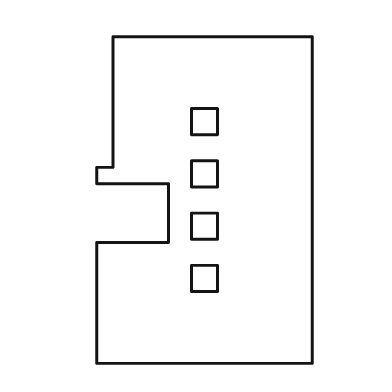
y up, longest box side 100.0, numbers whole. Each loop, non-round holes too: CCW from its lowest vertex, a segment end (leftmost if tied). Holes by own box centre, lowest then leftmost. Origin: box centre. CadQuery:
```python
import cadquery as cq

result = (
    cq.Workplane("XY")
    .moveTo(-33.0, -50.0)
    .lineTo(33.0, -50.0)
    .lineTo(33.0, 50.0)
    .lineTo(-28.0, 50.0)
    .lineTo(-28.0, 10.0)
    .lineTo(-33.0, 10.0)
    .lineTo(-33.0, 5.0)
    .lineTo(-11.0, 5.0)
    .lineTo(-11.0, -13.0)
    .lineTo(-33.0, -13.0)
    .close()
    .moveTo(-4.0, -28.0)
    .lineTo(4.0, -28.0)
    .lineTo(4.0, -20.0)
    .lineTo(-4.0, -20.0)
    .close()
    .moveTo(-4.0, -12.0)
    .lineTo(4.0, -12.0)
    .lineTo(4.0, -4.0)
    .lineTo(-4.0, -4.0)
    .close()
    .moveTo(-4.0, 4.0)
    .lineTo(4.0, 4.0)
    .lineTo(4.0, 12.0)
    .lineTo(-4.0, 12.0)
    .close()
    .moveTo(-4.0, 20.0)
    .lineTo(4.0, 20.0)
    .lineTo(4.0, 28.0)
    .lineTo(-4.0, 28.0)
    .close()
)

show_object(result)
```